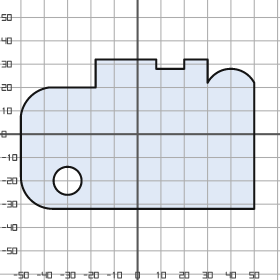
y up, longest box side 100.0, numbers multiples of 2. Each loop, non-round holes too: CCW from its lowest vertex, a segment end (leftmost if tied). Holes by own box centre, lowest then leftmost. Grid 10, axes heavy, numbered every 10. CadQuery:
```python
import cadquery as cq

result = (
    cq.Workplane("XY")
    .moveTo(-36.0, -32.0)
    .lineTo(50.0, -32.0)
    .lineTo(50.0, 22.0)
    .threePointArc((40.0, 28.0), (30.0, 22.0))
    .lineTo(30.0, 32.0)
    .lineTo(20.0, 32.0)
    .lineTo(20.0, 28.0)
    .lineTo(8.0, 28.0)
    .lineTo(8.0, 32.0)
    .lineTo(-18.0, 32.0)
    .lineTo(-18.0, 20.0)
    .lineTo(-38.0, 20.0)
    .threePointArc((-46.0, 16.0), (-50.0, 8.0))
    .lineTo(-50.0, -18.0)
    .threePointArc((-46.0, -28.0), (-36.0, -32.0))
    .close()
    .moveTo(-30.0, -20.0)
    .circle(6.0)
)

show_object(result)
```